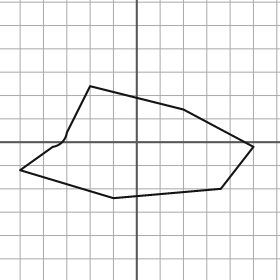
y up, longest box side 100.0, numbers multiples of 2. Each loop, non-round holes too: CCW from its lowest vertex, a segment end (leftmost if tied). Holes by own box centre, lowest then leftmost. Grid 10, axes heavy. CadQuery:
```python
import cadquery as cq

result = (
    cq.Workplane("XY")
    .moveTo(-10.0, -24.0)
    .lineTo(36.0, -20.0)
    .lineTo(50.0, -2.0)
    .lineTo(20.0, 14.0)
    .lineTo(-20.0, 24.0)
    .lineTo(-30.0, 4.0)
    .threePointArc((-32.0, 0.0), (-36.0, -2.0))
    .lineTo(-50.0, -12.0)
    .close()
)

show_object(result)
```